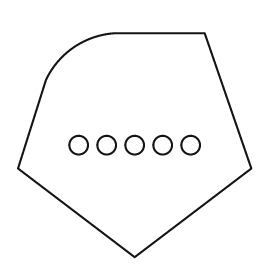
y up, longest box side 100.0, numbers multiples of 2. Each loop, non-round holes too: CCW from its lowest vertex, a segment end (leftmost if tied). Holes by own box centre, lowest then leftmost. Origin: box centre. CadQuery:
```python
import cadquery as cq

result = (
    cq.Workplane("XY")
    .moveTo(0.0, -48.0)
    .lineTo(50.0, -10.0)
    .lineTo(30.0, 48.0)
    .lineTo(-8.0, 48.0)
    .threePointArc((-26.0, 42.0), (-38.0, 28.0))
    .lineTo(-50.0, -10.0)
    .close()
    .moveTo(-24.0, 0.0)
    .circle(4.0)
    .moveTo(-12.0, 0.0)
    .circle(4.0)
    .moveTo(0.0, 0.0)
    .circle(4.0)
    .moveTo(12.0, 0.0)
    .circle(4.0)
    .moveTo(24.0, 0.0)
    .circle(4.0)
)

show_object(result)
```